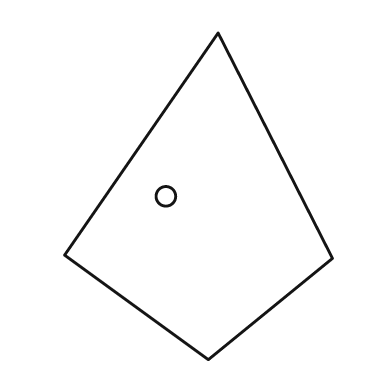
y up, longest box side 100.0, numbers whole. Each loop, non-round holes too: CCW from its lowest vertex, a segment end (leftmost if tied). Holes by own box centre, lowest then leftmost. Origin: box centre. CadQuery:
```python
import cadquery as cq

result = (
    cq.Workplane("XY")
    .moveTo(3.0, -50.0)
    .lineTo(41.0, -19.0)
    .lineTo(6.0, 50.0)
    .lineTo(-41.0, -18.0)
    .close()
    .moveTo(-10.0, 0.0)
    .circle(3.0)
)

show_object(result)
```